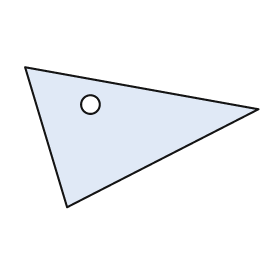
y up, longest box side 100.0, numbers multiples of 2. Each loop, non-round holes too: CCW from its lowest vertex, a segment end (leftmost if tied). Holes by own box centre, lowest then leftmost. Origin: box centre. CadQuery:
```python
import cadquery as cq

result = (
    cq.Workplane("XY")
    .moveTo(-32.0, -30.0)
    .lineTo(50.0, 12.0)
    .lineTo(-50.0, 30.0)
    .close()
    .moveTo(-22.0, 14.0)
    .circle(4.0)
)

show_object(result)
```